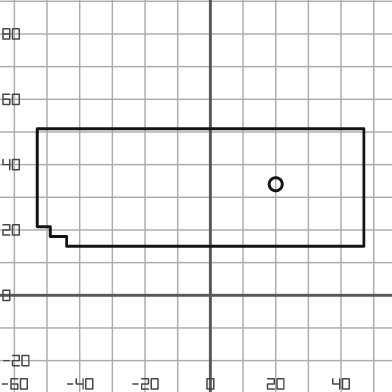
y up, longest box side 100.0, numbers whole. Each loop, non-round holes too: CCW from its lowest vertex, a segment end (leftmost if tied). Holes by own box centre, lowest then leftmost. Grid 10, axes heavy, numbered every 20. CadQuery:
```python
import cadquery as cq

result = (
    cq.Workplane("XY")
    .moveTo(-44.0, 15.0)
    .lineTo(47.0, 15.0)
    .lineTo(47.0, 51.0)
    .lineTo(-53.0, 51.0)
    .lineTo(-53.0, 21.0)
    .lineTo(-49.0, 21.0)
    .lineTo(-49.0, 18.0)
    .lineTo(-44.0, 18.0)
    .close()
    .moveTo(20.0, 34.0)
    .circle(2.0)
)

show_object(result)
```